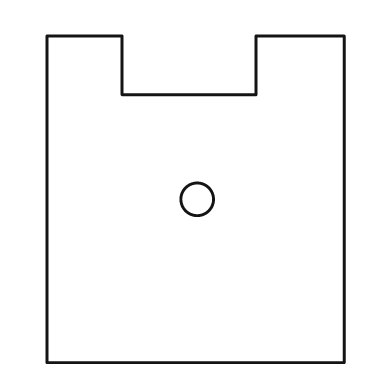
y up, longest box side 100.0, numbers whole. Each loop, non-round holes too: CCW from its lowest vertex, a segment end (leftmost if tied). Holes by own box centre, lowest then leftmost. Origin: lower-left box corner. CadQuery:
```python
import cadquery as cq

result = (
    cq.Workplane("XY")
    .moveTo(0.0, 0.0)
    .lineTo(91.0, 0.0)
    .lineTo(91.0, 100.0)
    .lineTo(64.0, 100.0)
    .lineTo(64.0, 82.0)
    .lineTo(23.0, 82.0)
    .lineTo(23.0, 100.0)
    .lineTo(0.0, 100.0)
    .close()
    .moveTo(46.0, 50.0)
    .circle(5.0)
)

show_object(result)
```